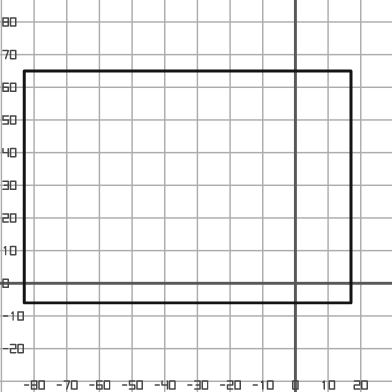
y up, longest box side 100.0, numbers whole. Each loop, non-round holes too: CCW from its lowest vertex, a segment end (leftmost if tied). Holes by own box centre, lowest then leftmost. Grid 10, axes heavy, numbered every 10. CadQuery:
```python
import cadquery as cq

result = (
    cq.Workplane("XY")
    .moveTo(-83.0, -6.0)
    .lineTo(17.0, -6.0)
    .lineTo(17.0, 65.0)
    .lineTo(-83.0, 65.0)
    .close()
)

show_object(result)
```